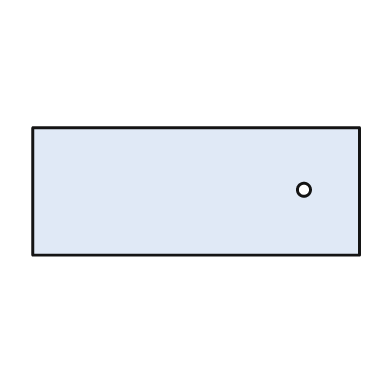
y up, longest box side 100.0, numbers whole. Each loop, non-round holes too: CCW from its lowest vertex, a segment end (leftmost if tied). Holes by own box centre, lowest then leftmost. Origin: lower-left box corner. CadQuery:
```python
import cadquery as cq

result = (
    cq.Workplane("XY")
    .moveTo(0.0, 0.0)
    .lineTo(100.0, 0.0)
    .lineTo(100.0, 39.0)
    .lineTo(0.0, 39.0)
    .close()
    .moveTo(83.0, 20.0)
    .circle(2.0)
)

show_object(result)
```